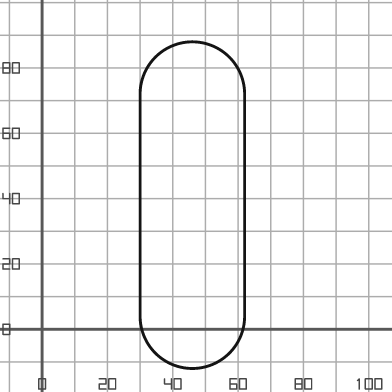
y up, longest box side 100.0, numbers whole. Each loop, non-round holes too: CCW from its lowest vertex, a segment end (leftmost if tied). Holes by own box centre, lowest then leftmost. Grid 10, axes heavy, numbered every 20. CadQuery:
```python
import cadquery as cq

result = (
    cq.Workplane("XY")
    .moveTo(30.0, 4.0)
    .threePointArc((46.0, -12.0), (62.0, 4.0))
    .lineTo(62.0, 72.0)
    .threePointArc((46.0, 88.0), (30.0, 72.0))
    .close()
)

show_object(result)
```